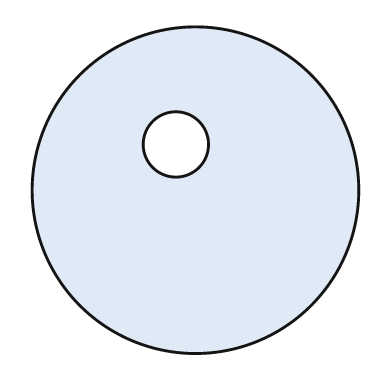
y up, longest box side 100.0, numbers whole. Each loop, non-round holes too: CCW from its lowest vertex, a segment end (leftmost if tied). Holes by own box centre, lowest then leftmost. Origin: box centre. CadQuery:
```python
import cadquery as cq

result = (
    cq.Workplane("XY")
    .moveTo(0.0, 0.0)
    .circle(50.0)
    .moveTo(-6.0, 14.0)
    .circle(10.0)
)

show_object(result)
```